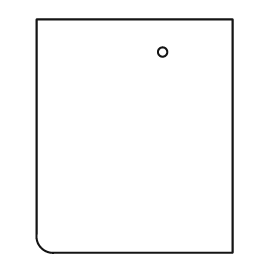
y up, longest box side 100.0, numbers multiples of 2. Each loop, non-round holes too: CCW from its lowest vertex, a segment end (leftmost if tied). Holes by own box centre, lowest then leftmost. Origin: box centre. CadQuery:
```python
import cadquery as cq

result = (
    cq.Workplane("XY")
    .moveTo(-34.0, -50.0)
    .lineTo(42.0, -50.0)
    .lineTo(42.0, 50.0)
    .lineTo(-42.0, 50.0)
    .lineTo(-42.0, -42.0)
    .threePointArc((-40.0, -48.0), (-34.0, -50.0))
    .close()
    .moveTo(12.0, 36.0)
    .circle(2.0)
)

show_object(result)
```